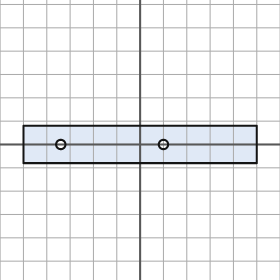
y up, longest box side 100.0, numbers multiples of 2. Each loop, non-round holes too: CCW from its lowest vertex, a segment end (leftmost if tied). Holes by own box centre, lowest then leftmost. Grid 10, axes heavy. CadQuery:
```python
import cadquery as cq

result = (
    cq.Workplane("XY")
    .moveTo(-50.0, -8.0)
    .lineTo(50.0, -8.0)
    .lineTo(50.0, 8.0)
    .lineTo(-50.0, 8.0)
    .close()
    .moveTo(-34.0, 0.0)
    .circle(2.0)
    .moveTo(10.0, 0.0)
    .circle(2.0)
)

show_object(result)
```